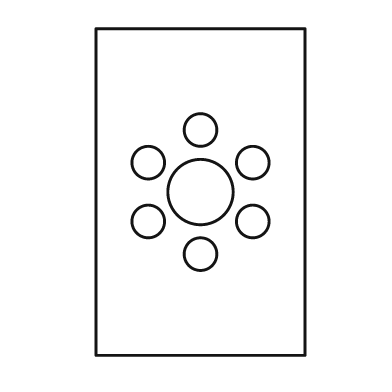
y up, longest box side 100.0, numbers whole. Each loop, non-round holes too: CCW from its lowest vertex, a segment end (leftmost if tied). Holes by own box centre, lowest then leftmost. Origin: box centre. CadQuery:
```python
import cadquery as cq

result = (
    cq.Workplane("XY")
    .moveTo(-32.0, -50.0)
    .lineTo(32.0, -50.0)
    .lineTo(32.0, 50.0)
    .lineTo(-32.0, 50.0)
    .close()
    .moveTo(0.0, -19.0)
    .circle(5.0)
    .moveTo(-16.0, -9.0)
    .circle(5.0)
    .moveTo(16.0, -9.0)
    .circle(5.0)
    .moveTo(0.0, 0.0)
    .circle(10.0)
    .moveTo(-16.0, 9.0)
    .circle(5.0)
    .moveTo(16.0, 9.0)
    .circle(5.0)
    .moveTo(0.0, 19.0)
    .circle(5.0)
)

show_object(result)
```